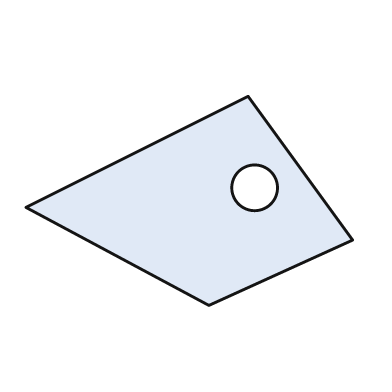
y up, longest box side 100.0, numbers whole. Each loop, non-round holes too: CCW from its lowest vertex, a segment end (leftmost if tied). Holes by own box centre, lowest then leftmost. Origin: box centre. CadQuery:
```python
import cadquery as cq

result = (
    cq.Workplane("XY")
    .moveTo(6.0, -32.0)
    .lineTo(50.0, -12.0)
    .lineTo(18.0, 32.0)
    .lineTo(-50.0, -2.0)
    .close()
    .moveTo(20.0, 4.0)
    .circle(7.0)
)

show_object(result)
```